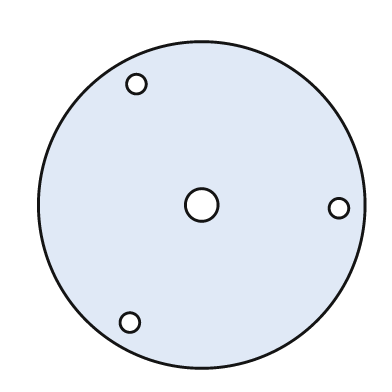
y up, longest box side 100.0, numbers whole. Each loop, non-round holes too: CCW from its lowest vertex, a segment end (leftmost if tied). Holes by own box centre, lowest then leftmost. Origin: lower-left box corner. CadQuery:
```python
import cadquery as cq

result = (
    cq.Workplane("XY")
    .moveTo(50.0, 50.0)
    .circle(50.0)
    .moveTo(28.0, 14.0)
    .circle(3.0)
    .moveTo(92.0, 49.0)
    .circle(3.0)
    .moveTo(50.0, 50.0)
    .circle(5.0)
    .moveTo(30.0, 87.0)
    .circle(3.0)
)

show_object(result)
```